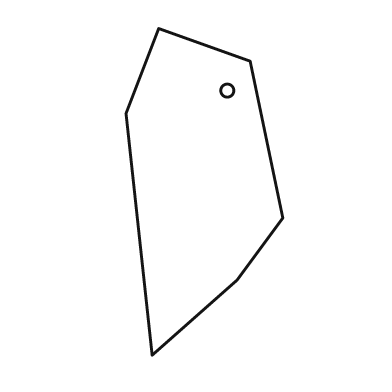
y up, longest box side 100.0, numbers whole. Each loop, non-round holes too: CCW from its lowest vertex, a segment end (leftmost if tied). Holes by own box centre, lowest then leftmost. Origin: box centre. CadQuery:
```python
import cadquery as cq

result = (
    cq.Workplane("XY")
    .moveTo(-16.0, -50.0)
    .lineTo(10.0, -27.0)
    .lineTo(24.0, -8.0)
    .lineTo(14.0, 40.0)
    .lineTo(-14.0, 50.0)
    .lineTo(-24.0, 24.0)
    .close()
    .moveTo(7.0, 31.0)
    .circle(2.0)
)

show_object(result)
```